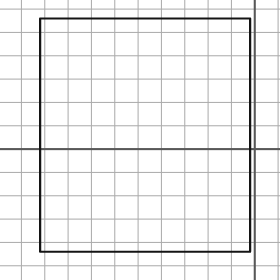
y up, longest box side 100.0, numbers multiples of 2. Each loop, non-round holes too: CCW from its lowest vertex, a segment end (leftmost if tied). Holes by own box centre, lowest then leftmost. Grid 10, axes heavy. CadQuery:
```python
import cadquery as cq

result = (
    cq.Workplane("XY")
    .moveTo(-92.0, -44.0)
    .lineTo(-2.0, -44.0)
    .lineTo(-2.0, 56.0)
    .lineTo(-92.0, 56.0)
    .close()
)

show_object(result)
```